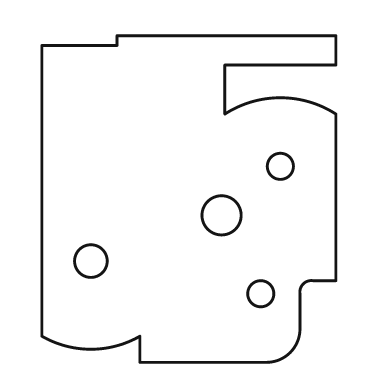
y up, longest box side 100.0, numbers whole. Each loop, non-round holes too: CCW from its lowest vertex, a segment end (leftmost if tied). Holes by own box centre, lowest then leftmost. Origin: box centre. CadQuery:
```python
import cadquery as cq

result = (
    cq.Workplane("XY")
    .moveTo(-15.0, -50.0)
    .lineTo(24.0, -50.0)
    .threePointArc((31.0, -47.0), (34.0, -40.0))
    .lineTo(34.0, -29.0)
    .threePointArc((35.0, -26.0), (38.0, -25.0))
    .lineTo(45.0, -25.0)
    .lineTo(45.0, 26.0)
    .threePointArc((28.0, 31.0), (11.0, 26.0))
    .lineTo(11.0, 41.0)
    .lineTo(45.0, 41.0)
    .lineTo(45.0, 50.0)
    .lineTo(-22.0, 50.0)
    .lineTo(-22.0, 47.0)
    .lineTo(-45.0, 47.0)
    .lineTo(-45.0, -42.0)
    .threePointArc((-30.0, -46.0), (-15.0, -42.0))
    .close()
    .moveTo(22.0, -29.0)
    .circle(4.0)
    .moveTo(-30.0, -19.0)
    .circle(5.0)
    .moveTo(10.0, -5.0)
    .circle(6.0)
    .moveTo(28.0, 10.0)
    .circle(4.0)
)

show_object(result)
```